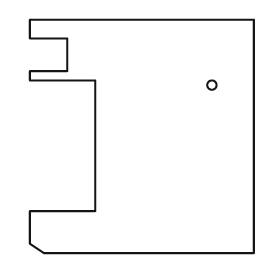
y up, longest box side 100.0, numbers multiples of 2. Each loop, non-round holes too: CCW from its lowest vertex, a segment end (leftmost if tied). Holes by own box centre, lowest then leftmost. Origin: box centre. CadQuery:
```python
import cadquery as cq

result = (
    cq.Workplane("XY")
    .moveTo(-42.0, -50.0)
    .lineTo(48.0, -50.0)
    .lineTo(48.0, 50.0)
    .lineTo(-48.0, 50.0)
    .lineTo(-48.0, 42.0)
    .lineTo(-32.0, 42.0)
    .lineTo(-32.0, 28.0)
    .lineTo(-48.0, 28.0)
    .lineTo(-48.0, 24.0)
    .lineTo(-20.0, 24.0)
    .lineTo(-20.0, -32.0)
    .lineTo(-48.0, -32.0)
    .lineTo(-48.0, -46.0)
    .close()
    .moveTo(30.0, 22.0)
    .circle(2.0)
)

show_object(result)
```